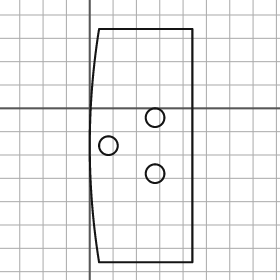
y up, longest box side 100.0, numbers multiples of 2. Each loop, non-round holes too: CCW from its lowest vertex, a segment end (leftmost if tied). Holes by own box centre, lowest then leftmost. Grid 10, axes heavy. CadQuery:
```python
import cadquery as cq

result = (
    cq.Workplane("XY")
    .moveTo(4.0, -66.0)
    .lineTo(44.0, -66.0)
    .lineTo(44.0, 34.0)
    .lineTo(4.0, 34.0)
    .threePointArc((0.0, -16.0), (4.0, -66.0))
    .close()
    .moveTo(28.0, -28.0)
    .circle(4.0)
    .moveTo(8.0, -16.0)
    .circle(4.0)
    .moveTo(28.0, -4.0)
    .circle(4.0)
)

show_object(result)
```